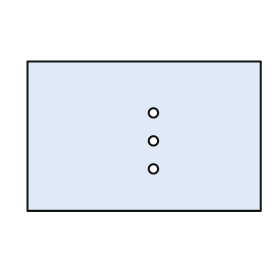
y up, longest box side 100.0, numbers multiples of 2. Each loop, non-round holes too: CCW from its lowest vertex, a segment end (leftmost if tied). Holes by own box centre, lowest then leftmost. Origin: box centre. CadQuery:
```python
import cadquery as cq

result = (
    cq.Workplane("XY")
    .moveTo(-50.0, -32.0)
    .lineTo(50.0, -32.0)
    .lineTo(50.0, 32.0)
    .lineTo(-50.0, 32.0)
    .close()
    .moveTo(4.0, -14.0)
    .circle(2.0)
    .moveTo(4.0, -2.0)
    .circle(2.0)
    .moveTo(4.0, 10.0)
    .circle(2.0)
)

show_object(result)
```